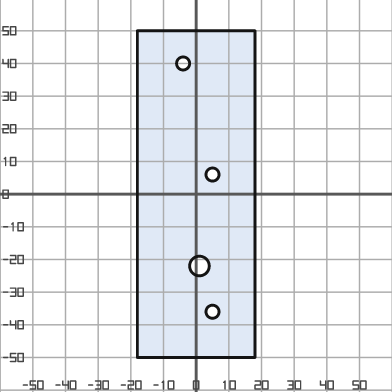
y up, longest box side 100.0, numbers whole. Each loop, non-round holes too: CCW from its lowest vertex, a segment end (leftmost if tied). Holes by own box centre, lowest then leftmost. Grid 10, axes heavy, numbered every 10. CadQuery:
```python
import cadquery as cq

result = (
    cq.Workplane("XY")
    .moveTo(-18.0, -50.0)
    .lineTo(18.0, -50.0)
    .lineTo(18.0, 50.0)
    .lineTo(-18.0, 50.0)
    .close()
    .moveTo(5.0, -36.0)
    .circle(2.0)
    .moveTo(1.0, -22.0)
    .circle(3.0)
    .moveTo(5.0, 6.0)
    .circle(2.0)
    .moveTo(-4.0, 40.0)
    .circle(2.0)
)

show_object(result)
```